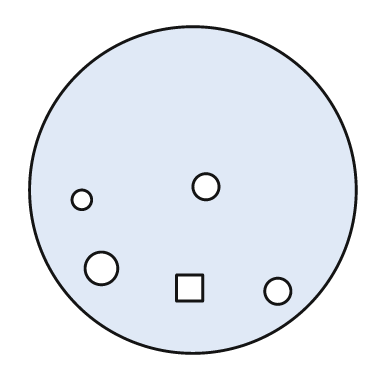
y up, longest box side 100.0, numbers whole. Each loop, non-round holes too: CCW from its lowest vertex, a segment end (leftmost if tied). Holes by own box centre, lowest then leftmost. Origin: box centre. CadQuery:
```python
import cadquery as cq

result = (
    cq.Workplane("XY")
    .moveTo(0.0, 0.0)
    .circle(50.0)
    .moveTo(26.0, -31.0)
    .circle(4.0)
    .moveTo(-5.0, -34.0)
    .lineTo(3.0, -34.0)
    .lineTo(3.0, -26.0)
    .lineTo(-5.0, -26.0)
    .close()
    .moveTo(-28.0, -24.0)
    .circle(5.0)
    .moveTo(-34.0, -3.0)
    .circle(3.0)
    .moveTo(4.0, 1.0)
    .circle(4.0)
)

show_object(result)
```